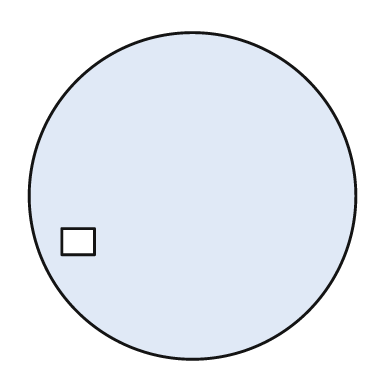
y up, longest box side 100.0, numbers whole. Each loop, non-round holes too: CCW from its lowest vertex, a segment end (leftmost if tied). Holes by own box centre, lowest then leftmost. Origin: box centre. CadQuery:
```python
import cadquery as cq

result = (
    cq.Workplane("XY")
    .moveTo(0.0, 0.0)
    .circle(50.0)
    .moveTo(-40.0, -18.0)
    .lineTo(-30.0, -18.0)
    .lineTo(-30.0, -10.0)
    .lineTo(-40.0, -10.0)
    .close()
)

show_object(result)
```